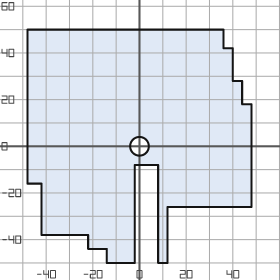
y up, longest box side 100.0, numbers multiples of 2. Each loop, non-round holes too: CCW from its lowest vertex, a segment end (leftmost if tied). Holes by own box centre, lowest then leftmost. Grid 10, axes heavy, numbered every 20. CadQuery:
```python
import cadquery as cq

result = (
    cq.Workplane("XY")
    .moveTo(-14.0, -50.0)
    .lineTo(-2.0, -50.0)
    .lineTo(-2.0, -8.0)
    .lineTo(8.0, -8.0)
    .lineTo(8.0, -50.0)
    .lineTo(12.0, -50.0)
    .lineTo(12.0, -26.0)
    .lineTo(48.0, -26.0)
    .lineTo(48.0, 18.0)
    .lineTo(44.0, 18.0)
    .lineTo(44.0, 28.0)
    .lineTo(40.0, 28.0)
    .lineTo(40.0, 42.0)
    .lineTo(36.0, 42.0)
    .lineTo(36.0, 50.0)
    .lineTo(-48.0, 50.0)
    .lineTo(-48.0, -16.0)
    .lineTo(-42.0, -16.0)
    .lineTo(-42.0, -38.0)
    .lineTo(-22.0, -38.0)
    .lineTo(-22.0, -44.0)
    .lineTo(-14.0, -44.0)
    .close()
    .moveTo(0.0, 0.0)
    .circle(4.0)
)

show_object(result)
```